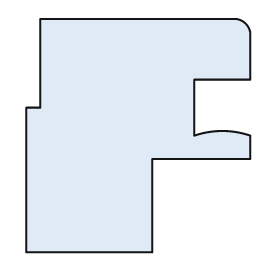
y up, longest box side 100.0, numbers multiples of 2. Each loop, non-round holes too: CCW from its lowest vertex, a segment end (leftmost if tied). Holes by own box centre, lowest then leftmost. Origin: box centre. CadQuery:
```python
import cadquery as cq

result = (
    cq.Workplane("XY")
    .moveTo(-48.0, -50.0)
    .lineTo(6.0, -50.0)
    .lineTo(6.0, -10.0)
    .lineTo(48.0, -10.0)
    .lineTo(48.0, 0.0)
    .threePointArc((36.0, 2.0), (24.0, 0.0))
    .lineTo(24.0, 24.0)
    .lineTo(48.0, 24.0)
    .lineTo(48.0, 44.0)
    .threePointArc((46.0, 48.0), (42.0, 50.0))
    .lineTo(-42.0, 50.0)
    .lineTo(-42.0, 12.0)
    .lineTo(-48.0, 12.0)
    .close()
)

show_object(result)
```